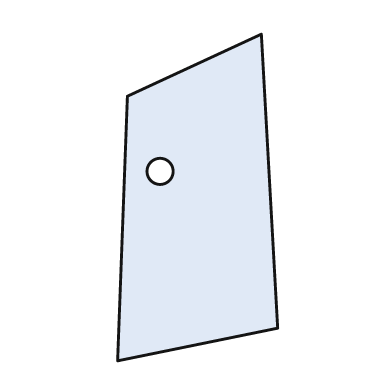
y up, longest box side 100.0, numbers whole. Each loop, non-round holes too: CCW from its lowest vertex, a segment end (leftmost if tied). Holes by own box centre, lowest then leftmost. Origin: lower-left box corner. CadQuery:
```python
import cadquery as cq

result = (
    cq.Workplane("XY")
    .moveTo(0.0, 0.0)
    .lineTo(49.0, 10.0)
    .lineTo(44.0, 100.0)
    .lineTo(3.0, 81.0)
    .close()
    .moveTo(13.0, 58.0)
    .circle(4.0)
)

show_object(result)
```